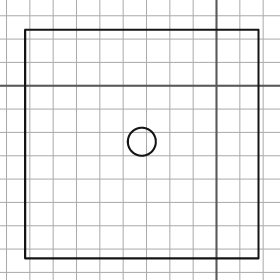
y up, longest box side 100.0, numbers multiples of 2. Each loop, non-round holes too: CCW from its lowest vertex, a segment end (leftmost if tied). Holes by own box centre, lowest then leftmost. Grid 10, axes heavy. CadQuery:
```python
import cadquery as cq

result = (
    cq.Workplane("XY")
    .moveTo(-82.0, -74.0)
    .lineTo(18.0, -74.0)
    .lineTo(18.0, 24.0)
    .lineTo(-82.0, 24.0)
    .close()
    .moveTo(-32.0, -24.0)
    .circle(6.0)
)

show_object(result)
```